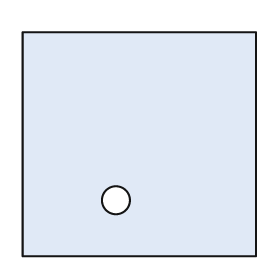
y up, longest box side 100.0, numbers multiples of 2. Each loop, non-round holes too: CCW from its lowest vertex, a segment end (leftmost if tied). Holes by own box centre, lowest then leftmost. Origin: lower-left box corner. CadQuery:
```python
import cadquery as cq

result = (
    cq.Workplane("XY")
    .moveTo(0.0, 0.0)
    .lineTo(100.0, 0.0)
    .lineTo(100.0, 96.0)
    .lineTo(0.0, 96.0)
    .close()
    .moveTo(40.0, 24.0)
    .circle(6.0)
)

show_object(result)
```